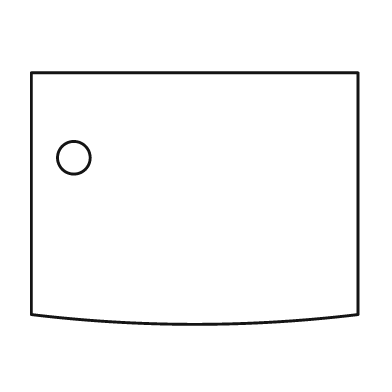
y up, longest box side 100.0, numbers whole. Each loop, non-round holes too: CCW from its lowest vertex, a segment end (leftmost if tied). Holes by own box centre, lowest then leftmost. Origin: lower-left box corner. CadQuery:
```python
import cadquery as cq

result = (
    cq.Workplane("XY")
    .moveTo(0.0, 3.0)
    .threePointArc((50.0, 0.0), (100.0, 3.0))
    .lineTo(100.0, 77.0)
    .lineTo(0.0, 77.0)
    .close()
    .moveTo(13.0, 51.0)
    .circle(5.0)
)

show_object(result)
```